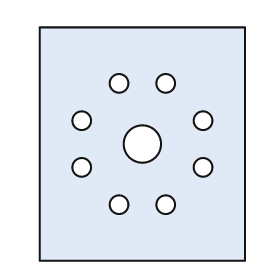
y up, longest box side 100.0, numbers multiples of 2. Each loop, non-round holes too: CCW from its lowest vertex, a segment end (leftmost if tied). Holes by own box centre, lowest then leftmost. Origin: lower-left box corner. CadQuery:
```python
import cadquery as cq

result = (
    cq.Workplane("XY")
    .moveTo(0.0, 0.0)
    .lineTo(88.0, 0.0)
    .lineTo(88.0, 100.0)
    .lineTo(0.0, 100.0)
    .close()
    .moveTo(34.0, 24.0)
    .circle(4.0)
    .moveTo(54.0, 24.0)
    .circle(4.0)
    .moveTo(18.0, 40.0)
    .circle(4.0)
    .moveTo(70.0, 40.0)
    .circle(4.0)
    .moveTo(44.0, 50.0)
    .circle(8.0)
    .moveTo(18.0, 60.0)
    .circle(4.0)
    .moveTo(70.0, 60.0)
    .circle(4.0)
    .moveTo(34.0, 76.0)
    .circle(4.0)
    .moveTo(54.0, 76.0)
    .circle(4.0)
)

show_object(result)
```